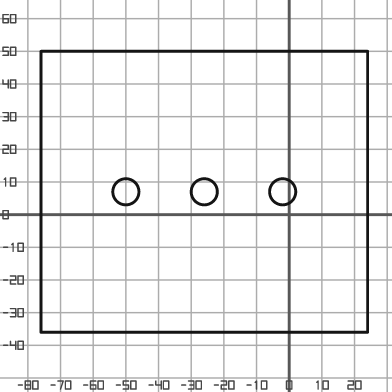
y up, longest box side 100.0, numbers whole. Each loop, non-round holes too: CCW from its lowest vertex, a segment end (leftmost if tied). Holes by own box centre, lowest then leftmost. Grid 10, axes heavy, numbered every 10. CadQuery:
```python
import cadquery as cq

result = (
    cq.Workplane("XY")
    .moveTo(-76.0, -36.0)
    .lineTo(24.0, -36.0)
    .lineTo(24.0, 50.0)
    .lineTo(-76.0, 50.0)
    .close()
    .moveTo(-50.0, 7.0)
    .circle(4.0)
    .moveTo(-26.0, 7.0)
    .circle(4.0)
    .moveTo(-2.0, 7.0)
    .circle(4.0)
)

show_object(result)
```